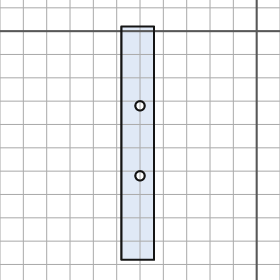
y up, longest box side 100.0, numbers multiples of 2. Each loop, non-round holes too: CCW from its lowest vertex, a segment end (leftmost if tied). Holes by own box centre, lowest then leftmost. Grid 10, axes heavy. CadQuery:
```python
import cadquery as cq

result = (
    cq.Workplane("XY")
    .moveTo(-58.0, -98.0)
    .lineTo(-44.0, -98.0)
    .lineTo(-44.0, 2.0)
    .lineTo(-58.0, 2.0)
    .close()
    .moveTo(-50.0, -62.0)
    .circle(2.0)
    .moveTo(-50.0, -32.0)
    .circle(2.0)
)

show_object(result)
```